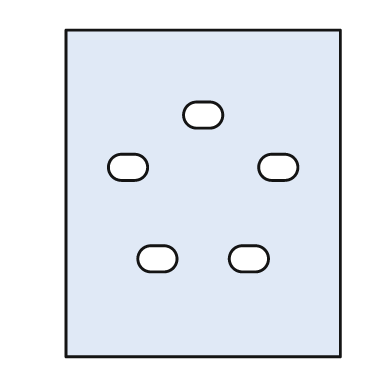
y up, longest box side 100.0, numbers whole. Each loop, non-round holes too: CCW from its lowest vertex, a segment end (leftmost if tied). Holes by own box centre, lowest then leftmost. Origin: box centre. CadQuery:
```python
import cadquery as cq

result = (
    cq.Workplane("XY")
    .moveTo(-42.0, -50.0)
    .lineTo(42.0, -50.0)
    .lineTo(42.0, 50.0)
    .lineTo(-42.0, 50.0)
    .close()
    .moveTo(-16.0, -24.0)
    .lineTo(-12.0, -24.0)
    .threePointArc((-8.0, -20.0), (-12.0, -16.0))
    .lineTo(-16.0, -16.0)
    .threePointArc((-20.0, -20.0), (-16.0, -24.0))
    .close()
    .moveTo(12.0, -24.0)
    .lineTo(16.0, -24.0)
    .threePointArc((20.0, -20.0), (16.0, -16.0))
    .lineTo(12.0, -16.0)
    .threePointArc((8.0, -20.0), (12.0, -24.0))
    .close()
    .moveTo(-25.0, 4.0)
    .lineTo(-21.0, 4.0)
    .threePointArc((-17.0, 8.0), (-21.0, 12.0))
    .lineTo(-25.0, 12.0)
    .threePointArc((-29.0, 8.0), (-25.0, 4.0))
    .close()
    .moveTo(21.0, 4.0)
    .lineTo(25.0, 4.0)
    .threePointArc((29.0, 8.0), (25.0, 12.0))
    .lineTo(21.0, 12.0)
    .threePointArc((17.0, 8.0), (21.0, 4.0))
    .close()
    .moveTo(-2.0, 20.0)
    .lineTo(2.0, 20.0)
    .threePointArc((6.0, 24.0), (2.0, 28.0))
    .lineTo(-2.0, 28.0)
    .threePointArc((-6.0, 24.0), (-2.0, 20.0))
    .close()
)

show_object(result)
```